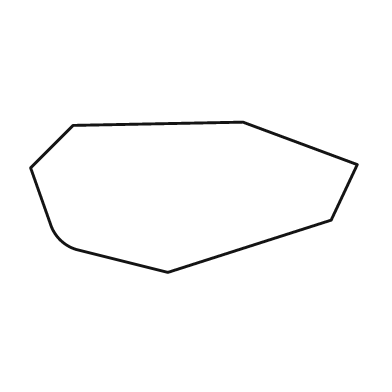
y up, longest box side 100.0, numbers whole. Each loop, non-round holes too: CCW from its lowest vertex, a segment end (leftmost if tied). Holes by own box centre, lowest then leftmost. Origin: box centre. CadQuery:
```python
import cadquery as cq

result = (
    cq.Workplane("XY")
    .moveTo(-8.0, -23.0)
    .lineTo(42.0, -7.0)
    .lineTo(50.0, 10.0)
    .lineTo(15.0, 23.0)
    .lineTo(-37.0, 22.0)
    .lineTo(-50.0, 9.0)
    .lineTo(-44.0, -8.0)
    .threePointArc((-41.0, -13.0), (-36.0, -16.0))
    .close()
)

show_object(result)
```